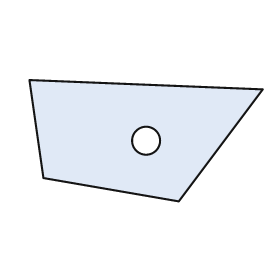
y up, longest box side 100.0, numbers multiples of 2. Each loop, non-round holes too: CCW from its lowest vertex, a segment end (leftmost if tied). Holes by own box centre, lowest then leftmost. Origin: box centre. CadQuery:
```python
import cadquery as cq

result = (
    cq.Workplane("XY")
    .moveTo(14.0, -26.0)
    .lineTo(50.0, 22.0)
    .lineTo(-50.0, 26.0)
    .lineTo(-44.0, -16.0)
    .close()
    .moveTo(0.0, 0.0)
    .circle(6.0)
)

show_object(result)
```